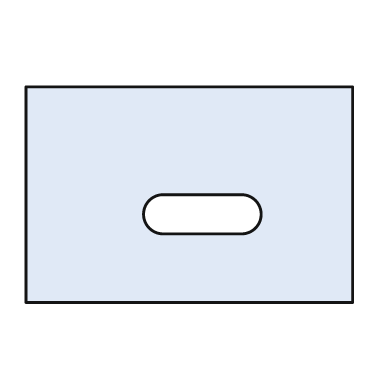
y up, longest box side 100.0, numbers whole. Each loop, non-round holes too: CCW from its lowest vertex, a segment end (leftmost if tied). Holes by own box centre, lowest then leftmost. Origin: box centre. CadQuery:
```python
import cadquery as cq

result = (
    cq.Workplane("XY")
    .moveTo(-50.0, -33.0)
    .lineTo(50.0, -33.0)
    .lineTo(50.0, 33.0)
    .lineTo(-50.0, 33.0)
    .close()
    .moveTo(-8.0, -12.0)
    .lineTo(16.0, -12.0)
    .threePointArc((22.0, -6.0), (16.0, 0.0))
    .lineTo(-8.0, 0.0)
    .threePointArc((-14.0, -6.0), (-8.0, -12.0))
    .close()
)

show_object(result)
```